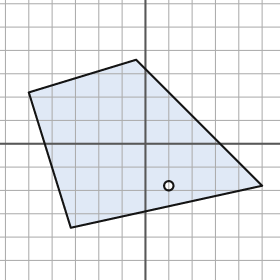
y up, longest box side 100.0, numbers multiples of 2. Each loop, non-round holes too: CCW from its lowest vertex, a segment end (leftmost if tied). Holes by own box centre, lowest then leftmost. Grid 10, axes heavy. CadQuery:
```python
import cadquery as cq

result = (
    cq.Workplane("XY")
    .moveTo(-32.0, -36.0)
    .lineTo(50.0, -18.0)
    .lineTo(-4.0, 36.0)
    .lineTo(-50.0, 22.0)
    .close()
    .moveTo(10.0, -18.0)
    .circle(2.0)
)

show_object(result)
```